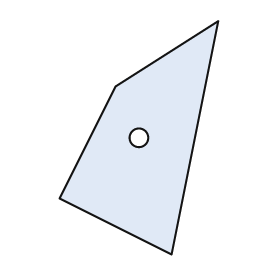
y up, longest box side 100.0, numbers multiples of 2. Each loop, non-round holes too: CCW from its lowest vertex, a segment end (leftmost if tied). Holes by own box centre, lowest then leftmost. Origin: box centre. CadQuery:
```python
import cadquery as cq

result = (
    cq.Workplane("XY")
    .moveTo(14.0, -50.0)
    .lineTo(34.0, 50.0)
    .lineTo(-10.0, 22.0)
    .lineTo(-34.0, -26.0)
    .close()
    .moveTo(0.0, 0.0)
    .circle(4.0)
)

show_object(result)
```